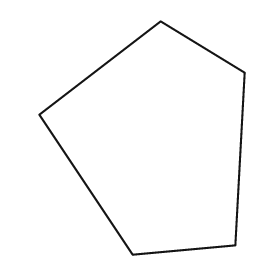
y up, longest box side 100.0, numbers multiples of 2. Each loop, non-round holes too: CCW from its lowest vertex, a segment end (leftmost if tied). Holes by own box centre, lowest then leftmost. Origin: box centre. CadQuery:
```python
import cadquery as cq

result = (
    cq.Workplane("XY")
    .moveTo(-4.0, -50.0)
    .lineTo(40.0, -46.0)
    .lineTo(44.0, 28.0)
    .lineTo(8.0, 50.0)
    .lineTo(-44.0, 10.0)
    .close()
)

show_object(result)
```